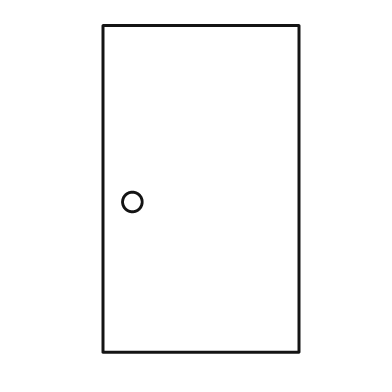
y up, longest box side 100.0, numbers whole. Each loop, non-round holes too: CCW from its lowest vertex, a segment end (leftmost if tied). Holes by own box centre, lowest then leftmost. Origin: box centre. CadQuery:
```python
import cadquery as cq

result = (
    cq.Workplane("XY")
    .moveTo(-30.0, -50.0)
    .lineTo(30.0, -50.0)
    .lineTo(30.0, 50.0)
    .lineTo(-30.0, 50.0)
    .close()
    .moveTo(-21.0, -4.0)
    .circle(3.0)
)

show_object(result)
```